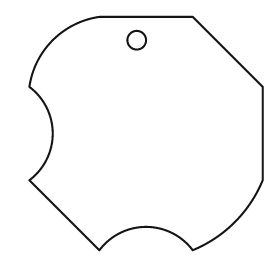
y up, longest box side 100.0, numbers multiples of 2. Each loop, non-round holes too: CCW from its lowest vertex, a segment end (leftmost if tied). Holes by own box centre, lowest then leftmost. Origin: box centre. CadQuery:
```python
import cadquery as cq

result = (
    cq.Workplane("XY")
    .moveTo(-20.0, -50.0)
    .threePointArc((0.0, -40.0), (20.0, -50.0))
    .threePointArc((38.0, -38.0), (50.0, -20.0))
    .lineTo(50.0, 20.0)
    .lineTo(20.0, 50.0)
    .lineTo(-20.0, 50.0)
    .threePointArc((-40.0, 40.0), (-50.0, 20.0))
    .threePointArc((-40.0, 0.0), (-50.0, -20.0))
    .close()
    .moveTo(-4.0, 40.0)
    .circle(4.0)
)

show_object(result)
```